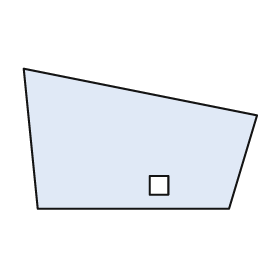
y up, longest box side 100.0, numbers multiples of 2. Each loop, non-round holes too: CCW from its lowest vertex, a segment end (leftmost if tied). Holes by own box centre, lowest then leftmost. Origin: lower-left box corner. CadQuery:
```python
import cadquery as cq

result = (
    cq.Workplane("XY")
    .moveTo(6.0, 0.0)
    .lineTo(88.0, 0.0)
    .lineTo(100.0, 40.0)
    .lineTo(0.0, 60.0)
    .close()
    .moveTo(54.0, 6.0)
    .lineTo(62.0, 6.0)
    .lineTo(62.0, 14.0)
    .lineTo(54.0, 14.0)
    .close()
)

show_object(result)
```